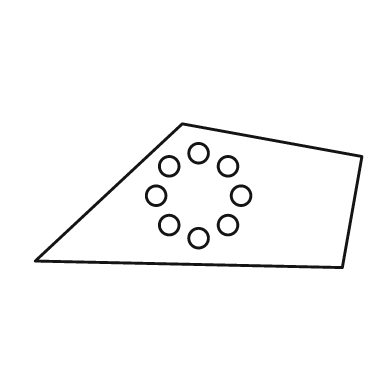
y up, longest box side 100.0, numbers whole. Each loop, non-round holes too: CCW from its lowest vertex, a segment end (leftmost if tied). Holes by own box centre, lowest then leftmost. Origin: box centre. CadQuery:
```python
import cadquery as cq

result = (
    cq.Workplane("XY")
    .moveTo(44.0, -22.0)
    .lineTo(50.0, 12.0)
    .lineTo(-5.0, 22.0)
    .lineTo(-50.0, -20.0)
    .close()
    .moveTo(0.0, -13.0)
    .circle(3.0)
    .moveTo(-9.0, -9.0)
    .circle(3.0)
    .moveTo(9.0, -9.0)
    .circle(3.0)
    .moveTo(-13.0, 0.0)
    .circle(3.0)
    .moveTo(13.0, 0.0)
    .circle(3.0)
    .moveTo(-9.0, 9.0)
    .circle(3.0)
    .moveTo(9.0, 9.0)
    .circle(3.0)
    .moveTo(0.0, 13.0)
    .circle(3.0)
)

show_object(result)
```